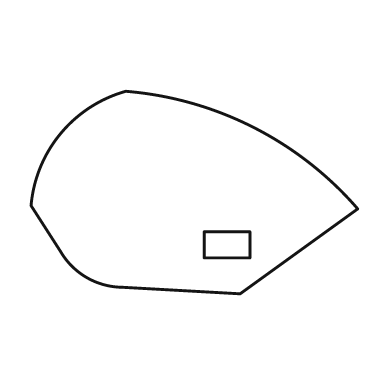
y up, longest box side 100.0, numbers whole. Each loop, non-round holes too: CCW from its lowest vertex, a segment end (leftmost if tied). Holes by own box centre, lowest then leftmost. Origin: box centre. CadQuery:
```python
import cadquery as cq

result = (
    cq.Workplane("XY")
    .moveTo(14.0, -31.0)
    .lineTo(50.0, -5.0)
    .threePointArc((18.0, 20.0), (-21.0, 31.0))
    .threePointArc((-41.0, 18.0), (-50.0, -4.0))
    .lineTo(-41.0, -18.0)
    .threePointArc((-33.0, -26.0), (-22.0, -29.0))
    .close()
    .moveTo(3.0, -20.0)
    .lineTo(17.0, -20.0)
    .lineTo(17.0, -12.0)
    .lineTo(3.0, -12.0)
    .close()
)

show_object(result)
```